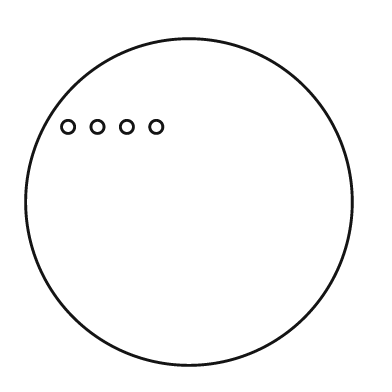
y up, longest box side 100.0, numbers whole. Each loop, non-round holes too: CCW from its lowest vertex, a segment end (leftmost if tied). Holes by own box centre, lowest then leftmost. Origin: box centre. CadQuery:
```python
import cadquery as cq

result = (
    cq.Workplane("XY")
    .moveTo(0.0, 0.0)
    .circle(50.0)
    .moveTo(-37.0, 23.0)
    .circle(2.0)
    .moveTo(-28.0, 23.0)
    .circle(2.0)
    .moveTo(-19.0, 23.0)
    .circle(2.0)
    .moveTo(-10.0, 23.0)
    .circle(2.0)
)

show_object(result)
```